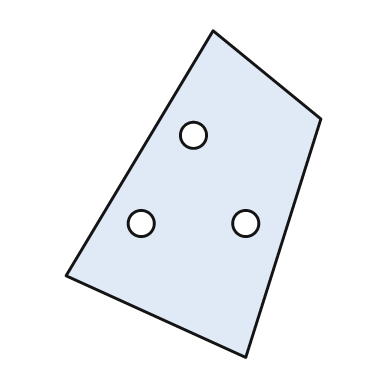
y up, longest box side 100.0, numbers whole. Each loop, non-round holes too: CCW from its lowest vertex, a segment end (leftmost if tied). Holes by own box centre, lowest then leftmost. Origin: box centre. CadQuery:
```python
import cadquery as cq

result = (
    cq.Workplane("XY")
    .moveTo(16.0, -50.0)
    .lineTo(39.0, 23.0)
    .lineTo(6.0, 50.0)
    .lineTo(-39.0, -25.0)
    .close()
    .moveTo(-16.0, -9.0)
    .circle(4.0)
    .moveTo(16.0, -9.0)
    .circle(4.0)
    .moveTo(0.0, 18.0)
    .circle(4.0)
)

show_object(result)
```